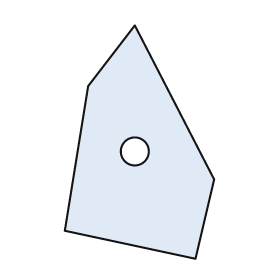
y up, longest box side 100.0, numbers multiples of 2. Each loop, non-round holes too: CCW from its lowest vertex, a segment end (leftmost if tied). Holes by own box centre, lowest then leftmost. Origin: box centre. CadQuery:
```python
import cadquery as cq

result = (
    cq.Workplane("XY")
    .moveTo(24.0, -50.0)
    .lineTo(32.0, -16.0)
    .lineTo(-2.0, 50.0)
    .lineTo(-22.0, 24.0)
    .lineTo(-32.0, -38.0)
    .close()
    .moveTo(-2.0, -4.0)
    .circle(6.0)
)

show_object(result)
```